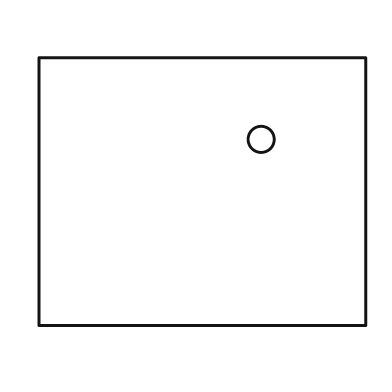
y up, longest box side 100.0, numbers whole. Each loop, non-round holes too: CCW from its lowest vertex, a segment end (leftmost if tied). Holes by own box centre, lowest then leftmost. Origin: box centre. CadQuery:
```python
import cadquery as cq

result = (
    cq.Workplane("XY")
    .moveTo(-50.0, -41.0)
    .lineTo(50.0, -41.0)
    .lineTo(50.0, 41.0)
    .lineTo(-50.0, 41.0)
    .close()
    .moveTo(18.0, 16.0)
    .circle(4.0)
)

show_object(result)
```